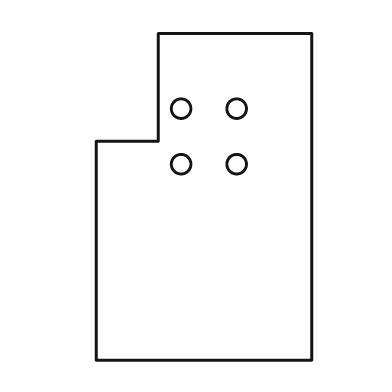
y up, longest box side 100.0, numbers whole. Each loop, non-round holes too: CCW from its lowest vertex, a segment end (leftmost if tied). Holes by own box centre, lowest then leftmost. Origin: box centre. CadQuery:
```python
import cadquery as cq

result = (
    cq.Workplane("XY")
    .moveTo(-33.0, -50.0)
    .lineTo(33.0, -50.0)
    .lineTo(33.0, 50.0)
    .lineTo(-14.0, 50.0)
    .lineTo(-14.0, 17.0)
    .lineTo(-33.0, 17.0)
    .close()
    .moveTo(-7.0, 10.0)
    .circle(3.0)
    .moveTo(10.0, 10.0)
    .circle(3.0)
    .moveTo(-7.0, 27.0)
    .circle(3.0)
    .moveTo(10.0, 27.0)
    .circle(3.0)
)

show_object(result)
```